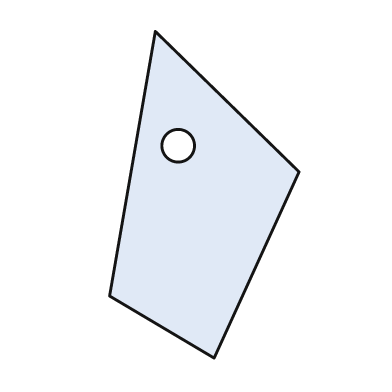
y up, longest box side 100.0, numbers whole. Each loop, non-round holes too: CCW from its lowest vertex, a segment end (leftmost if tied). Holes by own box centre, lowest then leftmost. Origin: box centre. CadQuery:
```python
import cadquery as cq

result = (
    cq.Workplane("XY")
    .moveTo(3.0, -50.0)
    .lineTo(29.0, 7.0)
    .lineTo(-15.0, 50.0)
    .lineTo(-29.0, -31.0)
    .close()
    .moveTo(-8.0, 15.0)
    .circle(5.0)
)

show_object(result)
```